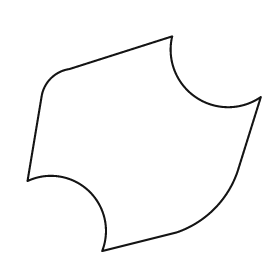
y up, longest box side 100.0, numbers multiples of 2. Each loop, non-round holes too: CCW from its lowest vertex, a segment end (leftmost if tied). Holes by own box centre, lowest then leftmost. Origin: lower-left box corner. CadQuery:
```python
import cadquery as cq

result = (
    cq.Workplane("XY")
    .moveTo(32.0, 0.0)
    .lineTo(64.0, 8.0)
    .threePointArc((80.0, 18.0), (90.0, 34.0))
    .lineTo(100.0, 66.0)
    .threePointArc((72.0, 66.0), (62.0, 92.0))
    .lineTo(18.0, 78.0)
    .threePointArc((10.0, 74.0), (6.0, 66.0))
    .lineTo(0.0, 30.0)
    .threePointArc((26.0, 26.0), (32.0, 0.0))
    .close()
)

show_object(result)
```